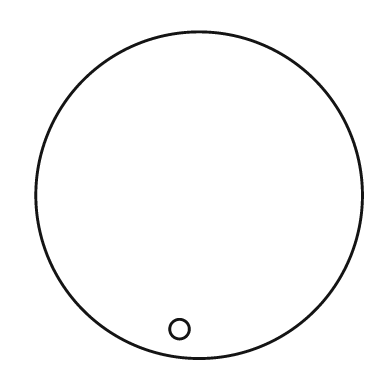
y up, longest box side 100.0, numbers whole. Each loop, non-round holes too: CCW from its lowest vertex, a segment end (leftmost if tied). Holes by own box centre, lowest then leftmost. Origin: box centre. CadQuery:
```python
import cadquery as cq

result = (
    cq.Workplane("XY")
    .moveTo(0.0, 0.0)
    .circle(50.0)
    .moveTo(-6.0, -41.0)
    .circle(3.0)
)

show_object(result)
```